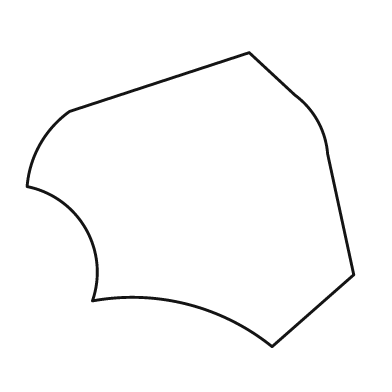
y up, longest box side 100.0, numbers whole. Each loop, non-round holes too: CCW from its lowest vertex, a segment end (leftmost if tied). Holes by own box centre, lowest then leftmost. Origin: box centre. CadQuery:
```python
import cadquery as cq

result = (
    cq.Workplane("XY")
    .moveTo(25.0, -45.0)
    .lineTo(50.0, -23.0)
    .lineTo(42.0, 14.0)
    .threePointArc((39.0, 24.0), (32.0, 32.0))
    .lineTo(18.0, 45.0)
    .lineTo(-37.0, 27.0)
    .threePointArc((-46.0, 17.0), (-50.0, 4.0))
    .threePointArc((-32.0, -9.0), (-30.0, -31.0))
    .threePointArc((-1.0, -32.0), (25.0, -45.0))
    .close()
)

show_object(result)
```